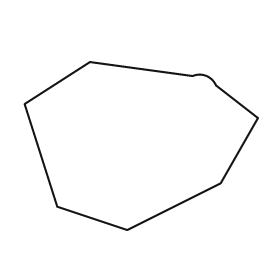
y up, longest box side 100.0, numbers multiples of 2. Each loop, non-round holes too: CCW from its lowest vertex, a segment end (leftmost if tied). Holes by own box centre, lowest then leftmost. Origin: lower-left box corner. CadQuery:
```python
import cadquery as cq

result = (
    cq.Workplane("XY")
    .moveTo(44.0, 0.0)
    .lineTo(84.0, 20.0)
    .lineTo(100.0, 48.0)
    .lineTo(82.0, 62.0)
    .threePointArc((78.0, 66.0), (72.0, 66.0))
    .lineTo(28.0, 72.0)
    .lineTo(0.0, 54.0)
    .lineTo(14.0, 10.0)
    .close()
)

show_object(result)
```